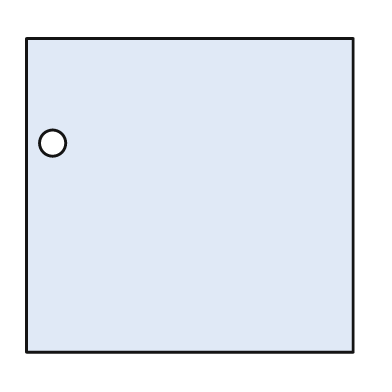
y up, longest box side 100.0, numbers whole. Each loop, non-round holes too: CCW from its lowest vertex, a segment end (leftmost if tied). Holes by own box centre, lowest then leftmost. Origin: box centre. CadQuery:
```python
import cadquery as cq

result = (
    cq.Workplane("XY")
    .moveTo(-50.0, -48.0)
    .lineTo(50.0, -48.0)
    .lineTo(50.0, 48.0)
    .lineTo(-50.0, 48.0)
    .close()
    .moveTo(-42.0, 16.0)
    .circle(4.0)
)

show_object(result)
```